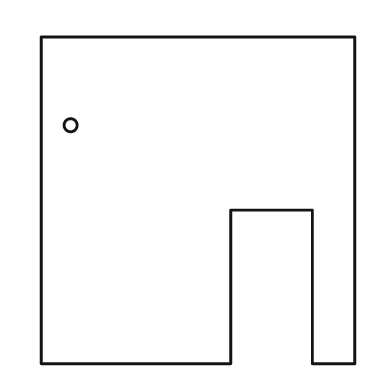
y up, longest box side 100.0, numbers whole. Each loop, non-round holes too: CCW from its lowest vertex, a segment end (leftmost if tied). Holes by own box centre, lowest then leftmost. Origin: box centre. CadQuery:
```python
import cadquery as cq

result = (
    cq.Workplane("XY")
    .moveTo(-48.0, -50.0)
    .lineTo(10.0, -50.0)
    .lineTo(10.0, -3.0)
    .lineTo(35.0, -3.0)
    .lineTo(35.0, -50.0)
    .lineTo(48.0, -50.0)
    .lineTo(48.0, 50.0)
    .lineTo(-48.0, 50.0)
    .close()
    .moveTo(-39.0, 23.0)
    .circle(2.0)
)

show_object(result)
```